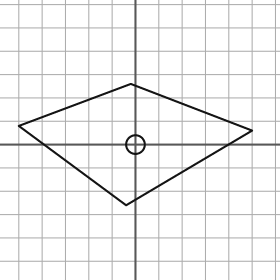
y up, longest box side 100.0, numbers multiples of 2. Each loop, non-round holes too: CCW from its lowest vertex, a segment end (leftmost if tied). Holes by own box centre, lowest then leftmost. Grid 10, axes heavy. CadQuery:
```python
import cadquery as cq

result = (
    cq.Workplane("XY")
    .moveTo(-4.0, -26.0)
    .lineTo(50.0, 6.0)
    .lineTo(-2.0, 26.0)
    .lineTo(-50.0, 8.0)
    .close()
    .moveTo(0.0, 0.0)
    .circle(4.0)
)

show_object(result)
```